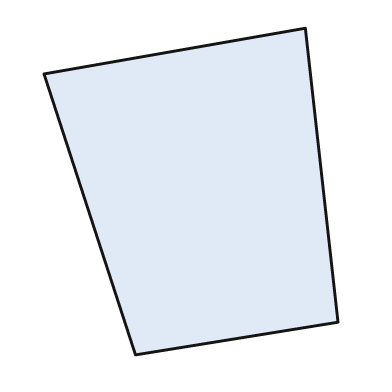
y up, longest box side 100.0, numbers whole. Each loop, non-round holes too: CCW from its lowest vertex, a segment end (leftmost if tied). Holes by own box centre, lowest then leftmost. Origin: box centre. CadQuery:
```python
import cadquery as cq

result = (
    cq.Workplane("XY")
    .moveTo(-17.0, -50.0)
    .lineTo(45.0, -40.0)
    .lineTo(35.0, 50.0)
    .lineTo(-45.0, 36.0)
    .close()
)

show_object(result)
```